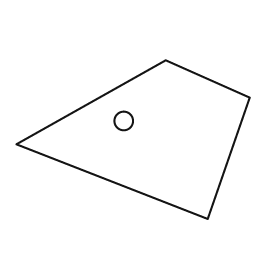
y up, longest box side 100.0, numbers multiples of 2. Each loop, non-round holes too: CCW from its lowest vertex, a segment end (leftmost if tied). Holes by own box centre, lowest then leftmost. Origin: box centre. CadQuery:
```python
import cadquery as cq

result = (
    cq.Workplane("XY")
    .moveTo(32.0, -34.0)
    .lineTo(50.0, 18.0)
    .lineTo(14.0, 34.0)
    .lineTo(-50.0, -2.0)
    .close()
    .moveTo(-4.0, 8.0)
    .circle(4.0)
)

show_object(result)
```